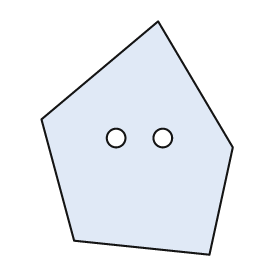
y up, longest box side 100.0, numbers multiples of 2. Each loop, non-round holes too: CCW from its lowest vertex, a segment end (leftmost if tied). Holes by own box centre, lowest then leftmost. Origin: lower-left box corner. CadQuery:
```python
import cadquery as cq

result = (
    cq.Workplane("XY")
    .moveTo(72.0, 0.0)
    .lineTo(82.0, 46.0)
    .lineTo(50.0, 100.0)
    .lineTo(0.0, 58.0)
    .lineTo(14.0, 6.0)
    .close()
    .moveTo(32.0, 50.0)
    .circle(4.0)
    .moveTo(52.0, 50.0)
    .circle(4.0)
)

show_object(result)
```